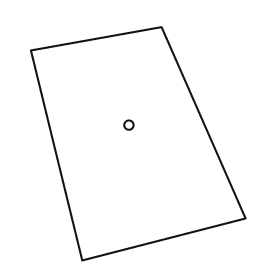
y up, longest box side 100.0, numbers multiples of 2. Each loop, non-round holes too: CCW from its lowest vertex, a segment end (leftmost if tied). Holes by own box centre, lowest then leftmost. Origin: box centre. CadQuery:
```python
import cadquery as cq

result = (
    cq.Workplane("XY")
    .moveTo(-24.0, -50.0)
    .lineTo(46.0, -32.0)
    .lineTo(10.0, 50.0)
    .lineTo(-46.0, 40.0)
    .close()
    .moveTo(-4.0, 8.0)
    .circle(2.0)
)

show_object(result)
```